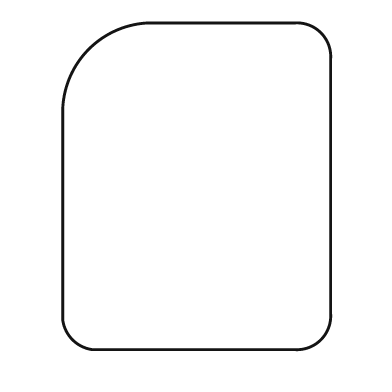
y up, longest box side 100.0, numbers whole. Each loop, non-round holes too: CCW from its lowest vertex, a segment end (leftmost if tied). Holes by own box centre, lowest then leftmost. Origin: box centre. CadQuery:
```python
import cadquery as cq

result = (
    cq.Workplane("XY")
    .moveTo(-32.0, -50.0)
    .lineTo(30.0, -50.0)
    .threePointArc((38.0, -47.0), (41.0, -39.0))
    .lineTo(41.0, 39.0)
    .threePointArc((38.0, 47.0), (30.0, 50.0))
    .lineTo(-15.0, 50.0)
    .threePointArc((-33.0, 42.0), (-41.0, 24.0))
    .lineTo(-41.0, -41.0)
    .threePointArc((-38.0, -47.0), (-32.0, -50.0))
    .close()
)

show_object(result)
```